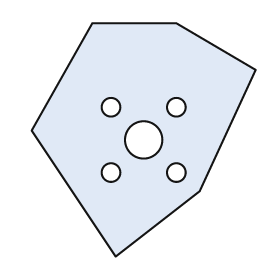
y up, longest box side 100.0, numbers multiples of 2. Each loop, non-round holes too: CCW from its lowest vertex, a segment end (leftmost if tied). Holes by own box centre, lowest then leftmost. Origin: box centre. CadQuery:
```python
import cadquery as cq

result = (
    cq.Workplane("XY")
    .moveTo(-12.0, -50.0)
    .lineTo(24.0, -22.0)
    .lineTo(48.0, 30.0)
    .lineTo(14.0, 50.0)
    .lineTo(-22.0, 50.0)
    .lineTo(-48.0, 4.0)
    .close()
    .moveTo(-14.0, -14.0)
    .circle(4.0)
    .moveTo(14.0, -14.0)
    .circle(4.0)
    .moveTo(0.0, 0.0)
    .circle(8.0)
    .moveTo(-14.0, 14.0)
    .circle(4.0)
    .moveTo(14.0, 14.0)
    .circle(4.0)
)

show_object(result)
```